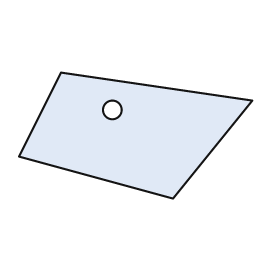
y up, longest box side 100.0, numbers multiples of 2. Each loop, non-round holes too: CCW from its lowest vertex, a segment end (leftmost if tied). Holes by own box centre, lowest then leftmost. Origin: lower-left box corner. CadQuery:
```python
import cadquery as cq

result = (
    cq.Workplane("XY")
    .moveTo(66.0, 0.0)
    .lineTo(100.0, 42.0)
    .lineTo(18.0, 54.0)
    .lineTo(0.0, 18.0)
    .close()
    .moveTo(40.0, 38.0)
    .circle(4.0)
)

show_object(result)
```